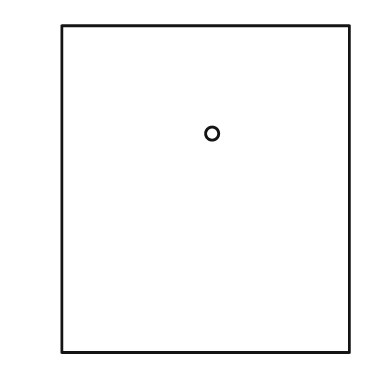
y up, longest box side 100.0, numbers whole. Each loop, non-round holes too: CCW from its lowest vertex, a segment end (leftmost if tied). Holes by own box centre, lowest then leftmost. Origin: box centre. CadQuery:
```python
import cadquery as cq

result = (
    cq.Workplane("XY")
    .moveTo(-44.0, -50.0)
    .lineTo(44.0, -50.0)
    .lineTo(44.0, 50.0)
    .lineTo(-44.0, 50.0)
    .close()
    .moveTo(2.0, 17.0)
    .circle(2.0)
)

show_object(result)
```